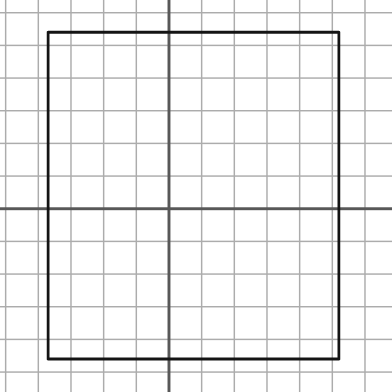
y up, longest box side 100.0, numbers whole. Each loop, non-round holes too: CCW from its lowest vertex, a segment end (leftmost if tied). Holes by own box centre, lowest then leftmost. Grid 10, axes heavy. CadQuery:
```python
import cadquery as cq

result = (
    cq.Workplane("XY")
    .moveTo(-37.0, -46.0)
    .lineTo(52.0, -46.0)
    .lineTo(52.0, 54.0)
    .lineTo(-37.0, 54.0)
    .close()
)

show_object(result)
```